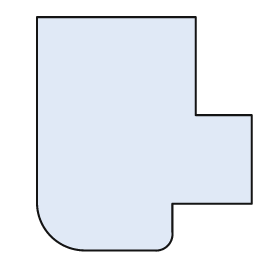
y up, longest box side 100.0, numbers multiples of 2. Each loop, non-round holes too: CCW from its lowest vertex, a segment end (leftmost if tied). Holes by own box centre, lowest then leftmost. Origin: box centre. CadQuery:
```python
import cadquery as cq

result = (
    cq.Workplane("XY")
    .moveTo(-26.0, -50.0)
    .lineTo(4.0, -50.0)
    .threePointArc((10.0, -48.0), (12.0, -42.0))
    .lineTo(12.0, -30.0)
    .lineTo(46.0, -30.0)
    .lineTo(46.0, 8.0)
    .lineTo(22.0, 8.0)
    .lineTo(22.0, 50.0)
    .lineTo(-46.0, 50.0)
    .lineTo(-46.0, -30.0)
    .threePointArc((-40.0, -44.0), (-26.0, -50.0))
    .close()
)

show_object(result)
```